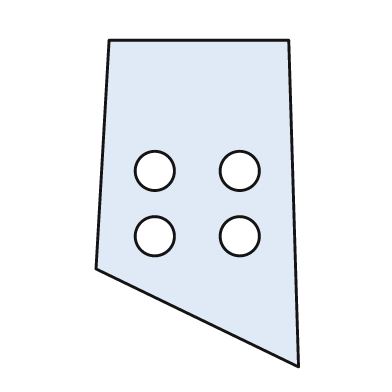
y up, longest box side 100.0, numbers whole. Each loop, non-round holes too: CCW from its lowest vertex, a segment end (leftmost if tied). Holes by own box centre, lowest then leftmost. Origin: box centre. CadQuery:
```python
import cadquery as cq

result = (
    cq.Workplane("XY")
    .moveTo(31.0, -50.0)
    .lineTo(28.0, 50.0)
    .lineTo(-27.0, 50.0)
    .lineTo(-31.0, -20.0)
    .close()
    .moveTo(-13.0, -10.0)
    .circle(6.0)
    .moveTo(13.0, -10.0)
    .circle(6.0)
    .moveTo(-13.0, 10.0)
    .circle(6.0)
    .moveTo(13.0, 10.0)
    .circle(6.0)
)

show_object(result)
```